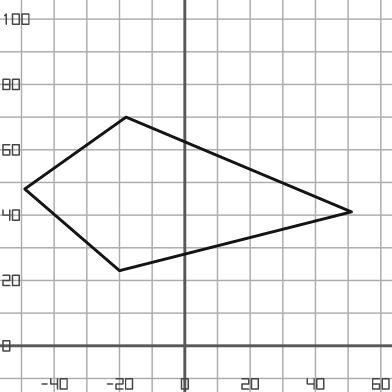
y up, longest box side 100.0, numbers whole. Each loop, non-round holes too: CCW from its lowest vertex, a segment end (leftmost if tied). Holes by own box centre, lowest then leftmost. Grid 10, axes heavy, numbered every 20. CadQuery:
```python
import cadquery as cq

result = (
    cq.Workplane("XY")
    .moveTo(-20.0, 23.0)
    .lineTo(51.0, 41.0)
    .lineTo(-18.0, 70.0)
    .lineTo(-49.0, 48.0)
    .close()
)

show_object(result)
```